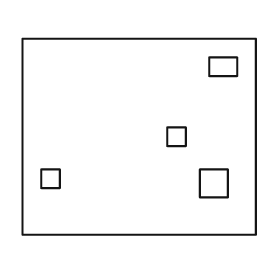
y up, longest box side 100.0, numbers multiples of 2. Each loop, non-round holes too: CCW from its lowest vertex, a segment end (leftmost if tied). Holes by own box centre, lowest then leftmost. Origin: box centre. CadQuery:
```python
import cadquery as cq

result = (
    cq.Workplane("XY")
    .moveTo(-50.0, -42.0)
    .lineTo(50.0, -42.0)
    .lineTo(50.0, 42.0)
    .lineTo(-50.0, 42.0)
    .close()
    .moveTo(26.0, -26.0)
    .lineTo(38.0, -26.0)
    .lineTo(38.0, -14.0)
    .lineTo(26.0, -14.0)
    .close()
    .moveTo(-42.0, -22.0)
    .lineTo(-34.0, -22.0)
    .lineTo(-34.0, -14.0)
    .lineTo(-42.0, -14.0)
    .close()
    .moveTo(12.0, -4.0)
    .lineTo(20.0, -4.0)
    .lineTo(20.0, 4.0)
    .lineTo(12.0, 4.0)
    .close()
    .moveTo(30.0, 26.0)
    .lineTo(42.0, 26.0)
    .lineTo(42.0, 34.0)
    .lineTo(30.0, 34.0)
    .close()
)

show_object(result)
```